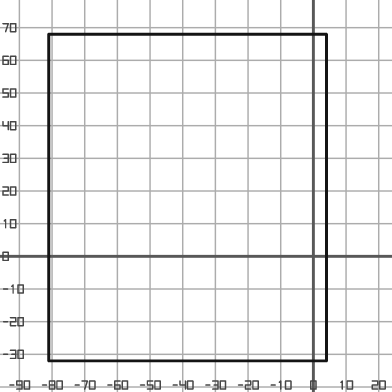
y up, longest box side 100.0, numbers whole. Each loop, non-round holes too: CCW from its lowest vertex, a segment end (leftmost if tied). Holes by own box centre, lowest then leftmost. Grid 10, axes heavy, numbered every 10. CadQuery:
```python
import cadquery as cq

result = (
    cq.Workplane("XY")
    .moveTo(-81.0, -32.0)
    .lineTo(4.0, -32.0)
    .lineTo(4.0, 68.0)
    .lineTo(-81.0, 68.0)
    .close()
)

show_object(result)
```